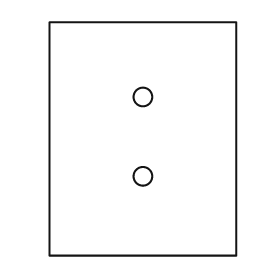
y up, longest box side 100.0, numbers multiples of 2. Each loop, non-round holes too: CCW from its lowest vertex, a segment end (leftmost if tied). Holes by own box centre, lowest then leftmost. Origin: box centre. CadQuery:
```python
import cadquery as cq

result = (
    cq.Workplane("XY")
    .moveTo(-40.0, -50.0)
    .lineTo(40.0, -50.0)
    .lineTo(40.0, 50.0)
    .lineTo(-40.0, 50.0)
    .close()
    .moveTo(0.0, -16.0)
    .circle(4.0)
    .moveTo(0.0, 18.0)
    .circle(4.0)
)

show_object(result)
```